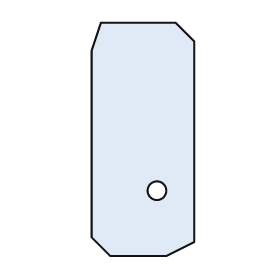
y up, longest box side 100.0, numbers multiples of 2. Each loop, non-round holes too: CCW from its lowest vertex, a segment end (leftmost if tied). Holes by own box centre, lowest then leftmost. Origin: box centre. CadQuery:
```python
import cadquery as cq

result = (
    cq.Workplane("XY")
    .moveTo(-14.0, -50.0)
    .lineTo(10.0, -50.0)
    .lineTo(22.0, -44.0)
    .lineTo(22.0, 42.0)
    .lineTo(14.0, 50.0)
    .lineTo(-18.0, 50.0)
    .lineTo(-22.0, 38.0)
    .lineTo(-22.0, -42.0)
    .close()
    .moveTo(6.0, -22.0)
    .circle(4.0)
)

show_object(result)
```